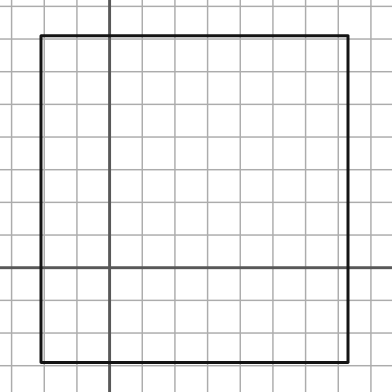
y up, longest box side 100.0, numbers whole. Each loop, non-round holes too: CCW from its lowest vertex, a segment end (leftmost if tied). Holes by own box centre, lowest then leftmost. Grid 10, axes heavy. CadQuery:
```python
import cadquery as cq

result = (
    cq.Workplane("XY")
    .moveTo(-21.0, -29.0)
    .lineTo(73.0, -29.0)
    .lineTo(73.0, 71.0)
    .lineTo(-21.0, 71.0)
    .close()
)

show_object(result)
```